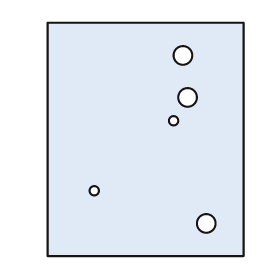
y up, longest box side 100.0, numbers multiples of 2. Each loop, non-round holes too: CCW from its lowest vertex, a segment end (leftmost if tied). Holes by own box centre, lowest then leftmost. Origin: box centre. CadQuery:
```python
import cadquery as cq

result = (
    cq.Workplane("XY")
    .moveTo(-42.0, -50.0)
    .lineTo(42.0, -50.0)
    .lineTo(42.0, 50.0)
    .lineTo(-42.0, 50.0)
    .close()
    .moveTo(26.0, -36.0)
    .circle(4.0)
    .moveTo(-22.0, -22.0)
    .circle(2.0)
    .moveTo(12.0, 8.0)
    .circle(2.0)
    .moveTo(18.0, 18.0)
    .circle(4.0)
    .moveTo(16.0, 36.0)
    .circle(4.0)
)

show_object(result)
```